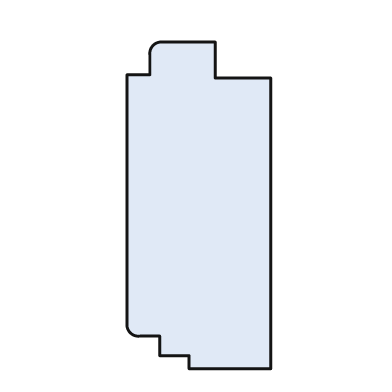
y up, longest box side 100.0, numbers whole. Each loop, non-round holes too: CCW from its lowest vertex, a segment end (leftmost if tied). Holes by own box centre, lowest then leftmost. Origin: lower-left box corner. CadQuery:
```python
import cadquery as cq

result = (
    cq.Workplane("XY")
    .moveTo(19.0, 0.0)
    .lineTo(44.0, 0.0)
    .lineTo(44.0, 89.0)
    .lineTo(27.0, 89.0)
    .lineTo(27.0, 100.0)
    .lineTo(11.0, 100.0)
    .threePointArc((8.0, 99.0), (7.0, 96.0))
    .lineTo(7.0, 90.0)
    .lineTo(0.0, 90.0)
    .lineTo(0.0, 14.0)
    .threePointArc((1.0, 11.0), (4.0, 10.0))
    .lineTo(10.0, 10.0)
    .lineTo(10.0, 4.0)
    .lineTo(19.0, 4.0)
    .close()
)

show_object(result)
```